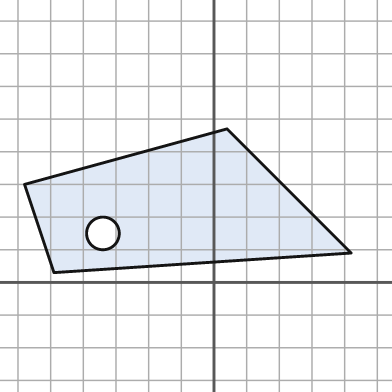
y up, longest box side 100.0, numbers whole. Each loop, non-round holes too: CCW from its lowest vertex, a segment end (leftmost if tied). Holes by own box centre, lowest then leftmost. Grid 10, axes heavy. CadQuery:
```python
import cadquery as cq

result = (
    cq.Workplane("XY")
    .moveTo(-49.0, 3.0)
    .lineTo(42.0, 9.0)
    .lineTo(4.0, 47.0)
    .lineTo(-58.0, 30.0)
    .close()
    .moveTo(-34.0, 15.0)
    .circle(5.0)
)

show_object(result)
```